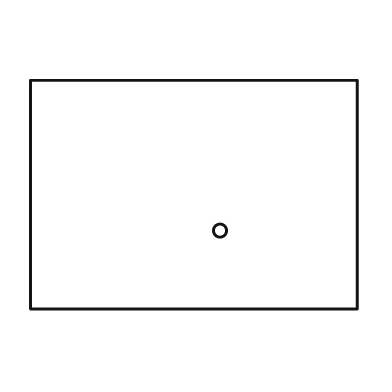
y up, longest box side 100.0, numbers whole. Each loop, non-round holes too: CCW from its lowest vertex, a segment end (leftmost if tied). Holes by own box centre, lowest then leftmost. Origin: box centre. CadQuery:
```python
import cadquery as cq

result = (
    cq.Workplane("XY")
    .moveTo(-50.0, -35.0)
    .lineTo(50.0, -35.0)
    .lineTo(50.0, 35.0)
    .lineTo(-50.0, 35.0)
    .close()
    .moveTo(8.0, -11.0)
    .circle(2.0)
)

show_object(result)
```